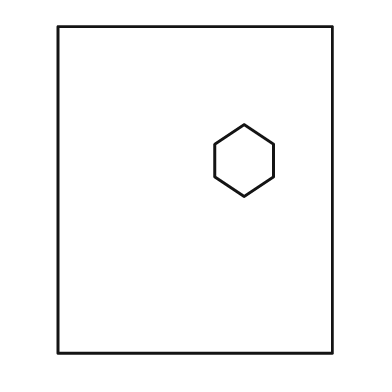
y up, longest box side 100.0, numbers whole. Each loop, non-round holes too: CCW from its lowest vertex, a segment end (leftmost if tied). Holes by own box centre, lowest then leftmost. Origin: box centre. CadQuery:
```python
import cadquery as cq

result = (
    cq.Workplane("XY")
    .moveTo(-42.0, -50.0)
    .lineTo(42.0, -50.0)
    .lineTo(42.0, 50.0)
    .lineTo(-42.0, 50.0)
    .close()
    .moveTo(15.0, -2.0)
    .lineTo(24.0, 4.0)
    .lineTo(24.0, 14.0)
    .lineTo(15.0, 20.0)
    .lineTo(6.0, 14.0)
    .lineTo(6.0, 4.0)
    .close()
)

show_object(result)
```